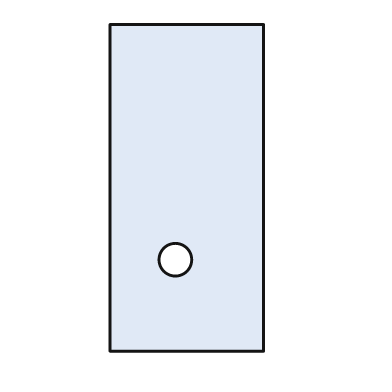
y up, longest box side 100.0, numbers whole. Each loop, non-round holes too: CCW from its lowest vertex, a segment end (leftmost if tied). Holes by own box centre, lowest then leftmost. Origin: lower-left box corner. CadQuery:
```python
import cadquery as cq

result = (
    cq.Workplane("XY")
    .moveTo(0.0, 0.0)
    .lineTo(47.0, 0.0)
    .lineTo(47.0, 100.0)
    .lineTo(0.0, 100.0)
    .close()
    .moveTo(20.0, 28.0)
    .circle(5.0)
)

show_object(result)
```